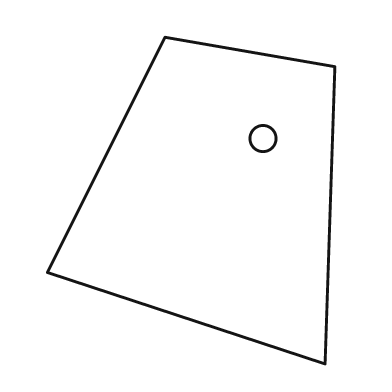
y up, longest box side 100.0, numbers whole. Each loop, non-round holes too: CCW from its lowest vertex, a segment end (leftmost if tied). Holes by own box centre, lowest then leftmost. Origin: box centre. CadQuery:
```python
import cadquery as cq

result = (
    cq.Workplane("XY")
    .moveTo(41.0, -50.0)
    .lineTo(44.0, 41.0)
    .lineTo(-8.0, 50.0)
    .lineTo(-44.0, -22.0)
    .close()
    .moveTo(22.0, 19.0)
    .circle(4.0)
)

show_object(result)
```